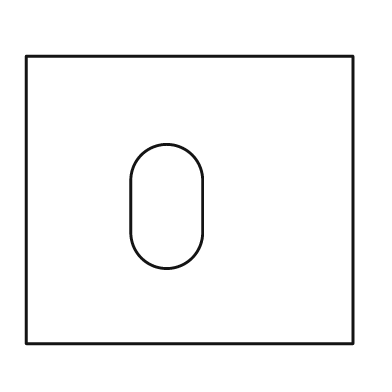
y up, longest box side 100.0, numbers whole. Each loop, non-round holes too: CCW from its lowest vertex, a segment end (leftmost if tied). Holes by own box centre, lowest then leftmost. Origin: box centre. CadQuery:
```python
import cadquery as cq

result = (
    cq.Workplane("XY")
    .moveTo(-50.0, -44.0)
    .lineTo(50.0, -44.0)
    .lineTo(50.0, 44.0)
    .lineTo(-50.0, 44.0)
    .close()
    .moveTo(-18.0, -10.0)
    .threePointArc((-7.0, -21.0), (4.0, -10.0))
    .lineTo(4.0, 6.0)
    .threePointArc((-7.0, 17.0), (-18.0, 6.0))
    .close()
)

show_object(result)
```